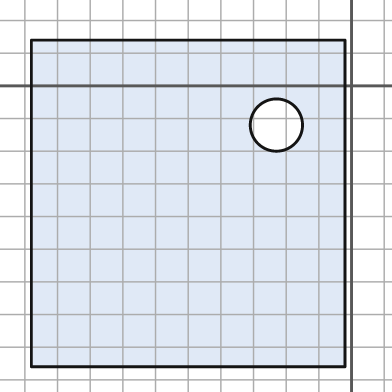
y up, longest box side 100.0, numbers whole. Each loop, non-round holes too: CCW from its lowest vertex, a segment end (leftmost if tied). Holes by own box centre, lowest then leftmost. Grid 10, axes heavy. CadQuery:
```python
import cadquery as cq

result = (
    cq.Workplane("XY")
    .moveTo(-98.0, -86.0)
    .lineTo(-2.0, -86.0)
    .lineTo(-2.0, 14.0)
    .lineTo(-98.0, 14.0)
    .close()
    .moveTo(-23.0, -12.0)
    .circle(8.0)
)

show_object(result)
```